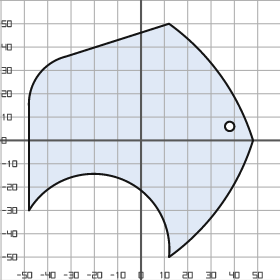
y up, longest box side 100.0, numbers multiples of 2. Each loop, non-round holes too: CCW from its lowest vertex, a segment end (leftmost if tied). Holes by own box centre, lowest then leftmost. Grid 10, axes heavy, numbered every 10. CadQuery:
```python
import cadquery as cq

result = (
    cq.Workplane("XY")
    .moveTo(12.0, -50.0)
    .threePointArc((34.0, -28.0), (48.0, 0.0))
    .threePointArc((34.0, 28.0), (12.0, 50.0))
    .lineTo(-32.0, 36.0)
    .threePointArc((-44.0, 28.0), (-48.0, 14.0))
    .lineTo(-48.0, -30.0)
    .threePointArc((-10.0, -16.0), (12.0, -50.0))
    .close()
    .moveTo(38.0, 6.0)
    .circle(2.0)
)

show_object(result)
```